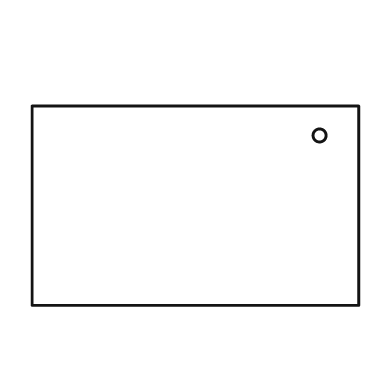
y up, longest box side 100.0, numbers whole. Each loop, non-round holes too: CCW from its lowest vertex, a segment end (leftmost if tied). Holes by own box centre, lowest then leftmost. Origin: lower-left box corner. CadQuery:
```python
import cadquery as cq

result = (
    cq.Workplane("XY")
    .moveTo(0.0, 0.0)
    .lineTo(100.0, 0.0)
    .lineTo(100.0, 61.0)
    .lineTo(0.0, 61.0)
    .close()
    .moveTo(88.0, 52.0)
    .circle(2.0)
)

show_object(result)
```